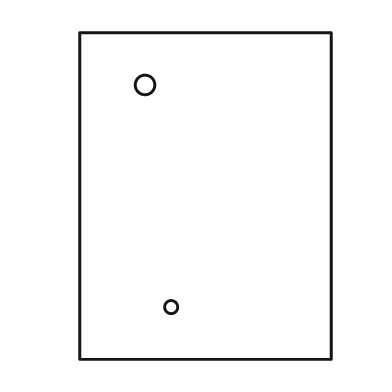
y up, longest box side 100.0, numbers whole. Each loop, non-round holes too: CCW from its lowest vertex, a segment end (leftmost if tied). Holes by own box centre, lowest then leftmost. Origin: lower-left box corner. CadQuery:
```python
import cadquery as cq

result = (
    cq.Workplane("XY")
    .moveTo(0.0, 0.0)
    .lineTo(77.0, 0.0)
    .lineTo(77.0, 100.0)
    .lineTo(0.0, 100.0)
    .close()
    .moveTo(28.0, 16.0)
    .circle(2.0)
    .moveTo(20.0, 84.0)
    .circle(3.0)
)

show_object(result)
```